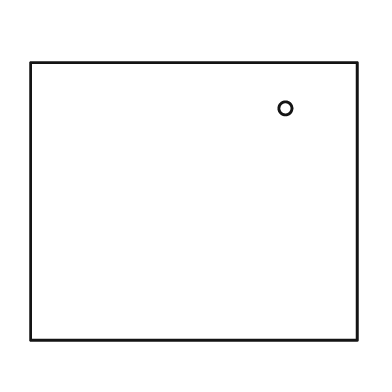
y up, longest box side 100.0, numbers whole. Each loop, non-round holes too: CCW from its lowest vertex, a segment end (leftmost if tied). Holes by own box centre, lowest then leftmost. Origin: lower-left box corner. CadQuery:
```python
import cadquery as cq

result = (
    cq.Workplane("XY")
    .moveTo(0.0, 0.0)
    .lineTo(100.0, 0.0)
    .lineTo(100.0, 85.0)
    .lineTo(0.0, 85.0)
    .close()
    .moveTo(78.0, 71.0)
    .circle(2.0)
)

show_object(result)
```